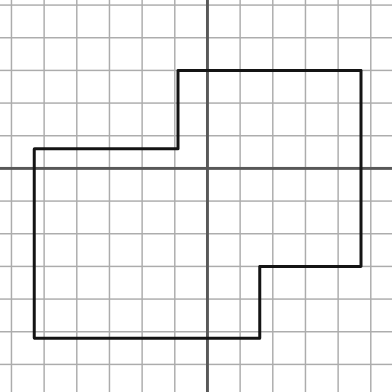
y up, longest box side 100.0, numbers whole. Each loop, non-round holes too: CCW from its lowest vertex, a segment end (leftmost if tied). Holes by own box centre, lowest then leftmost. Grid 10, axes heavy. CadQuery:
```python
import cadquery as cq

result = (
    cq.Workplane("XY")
    .moveTo(-53.0, -52.0)
    .lineTo(16.0, -52.0)
    .lineTo(16.0, -30.0)
    .lineTo(47.0, -30.0)
    .lineTo(47.0, 30.0)
    .lineTo(-9.0, 30.0)
    .lineTo(-9.0, 6.0)
    .lineTo(-53.0, 6.0)
    .close()
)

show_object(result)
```